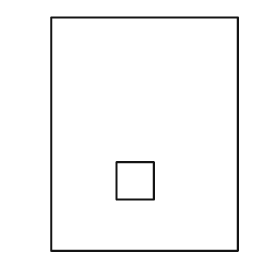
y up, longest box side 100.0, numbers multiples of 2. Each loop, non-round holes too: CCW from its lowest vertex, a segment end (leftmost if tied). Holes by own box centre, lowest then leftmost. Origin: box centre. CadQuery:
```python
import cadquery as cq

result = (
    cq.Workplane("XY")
    .moveTo(-40.0, -50.0)
    .lineTo(40.0, -50.0)
    .lineTo(40.0, 50.0)
    .lineTo(-40.0, 50.0)
    .close()
    .moveTo(-12.0, -28.0)
    .lineTo(4.0, -28.0)
    .lineTo(4.0, -12.0)
    .lineTo(-12.0, -12.0)
    .close()
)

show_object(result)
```